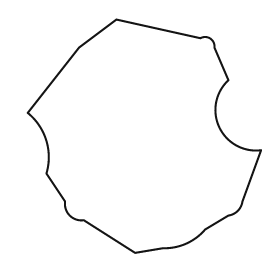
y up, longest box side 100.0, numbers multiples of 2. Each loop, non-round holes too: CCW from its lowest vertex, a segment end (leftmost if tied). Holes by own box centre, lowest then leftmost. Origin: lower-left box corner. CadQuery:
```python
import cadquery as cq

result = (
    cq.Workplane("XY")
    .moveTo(46.0, 0.0)
    .lineTo(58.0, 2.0)
    .threePointArc((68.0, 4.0), (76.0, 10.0))
    .lineTo(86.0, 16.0)
    .threePointArc((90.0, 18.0), (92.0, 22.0))
    .lineTo(100.0, 44.0)
    .threePointArc((82.0, 54.0), (86.0, 74.0))
    .lineTo(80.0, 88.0)
    .threePointArc((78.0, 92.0), (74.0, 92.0))
    .lineTo(38.0, 100.0)
    .lineTo(22.0, 88.0)
    .lineTo(0.0, 60.0)
    .threePointArc((8.0, 48.0), (8.0, 34.0))
    .lineTo(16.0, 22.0)
    .threePointArc((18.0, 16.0), (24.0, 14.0))
    .close()
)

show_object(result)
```